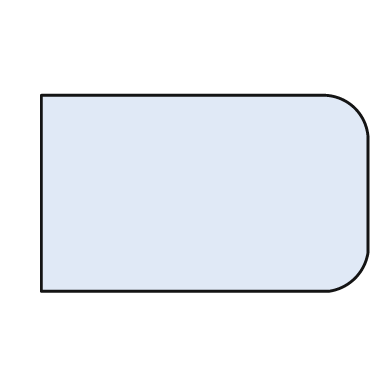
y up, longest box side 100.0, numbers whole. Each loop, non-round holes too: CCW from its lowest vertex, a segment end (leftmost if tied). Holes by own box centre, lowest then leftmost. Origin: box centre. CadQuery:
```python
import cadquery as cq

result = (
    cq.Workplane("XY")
    .moveTo(-50.0, -30.0)
    .lineTo(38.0, -30.0)
    .threePointArc((46.0, -26.0), (50.0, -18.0))
    .lineTo(50.0, 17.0)
    .threePointArc((46.0, 26.0), (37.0, 30.0))
    .lineTo(-50.0, 30.0)
    .close()
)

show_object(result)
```